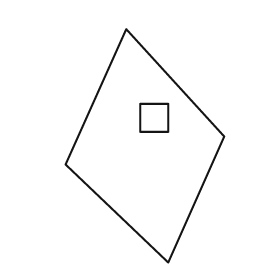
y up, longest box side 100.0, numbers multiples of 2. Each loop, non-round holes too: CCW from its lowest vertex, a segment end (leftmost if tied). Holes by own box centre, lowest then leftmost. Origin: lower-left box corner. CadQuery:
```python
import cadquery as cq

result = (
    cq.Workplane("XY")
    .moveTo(44.0, 0.0)
    .lineTo(68.0, 54.0)
    .lineTo(26.0, 100.0)
    .lineTo(0.0, 42.0)
    .close()
    .moveTo(32.0, 56.0)
    .lineTo(44.0, 56.0)
    .lineTo(44.0, 68.0)
    .lineTo(32.0, 68.0)
    .close()
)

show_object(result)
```